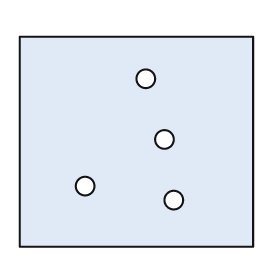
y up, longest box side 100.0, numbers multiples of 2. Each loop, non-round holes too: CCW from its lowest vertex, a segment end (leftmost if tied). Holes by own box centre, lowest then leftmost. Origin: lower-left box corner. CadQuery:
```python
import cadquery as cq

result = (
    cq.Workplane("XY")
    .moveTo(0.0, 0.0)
    .lineTo(100.0, 0.0)
    .lineTo(100.0, 90.0)
    .lineTo(0.0, 90.0)
    .close()
    .moveTo(66.0, 20.0)
    .circle(4.0)
    .moveTo(28.0, 26.0)
    .circle(4.0)
    .moveTo(62.0, 46.0)
    .circle(4.0)
    .moveTo(54.0, 72.0)
    .circle(4.0)
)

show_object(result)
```